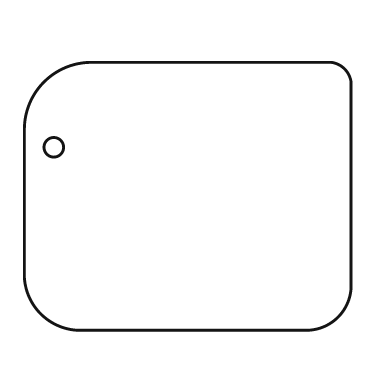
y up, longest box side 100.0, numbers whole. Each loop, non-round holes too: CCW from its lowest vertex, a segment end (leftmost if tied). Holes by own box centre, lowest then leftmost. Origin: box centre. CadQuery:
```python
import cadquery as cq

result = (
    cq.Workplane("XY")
    .moveTo(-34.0, -41.0)
    .lineTo(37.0, -41.0)
    .threePointArc((46.0, -37.0), (50.0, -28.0))
    .lineTo(50.0, 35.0)
    .threePointArc((48.0, 39.0), (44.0, 41.0))
    .lineTo(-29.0, 41.0)
    .threePointArc((-44.0, 35.0), (-50.0, 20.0))
    .lineTo(-50.0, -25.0)
    .threePointArc((-45.0, -36.0), (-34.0, -41.0))
    .close()
    .moveTo(-41.0, 15.0)
    .circle(3.0)
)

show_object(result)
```